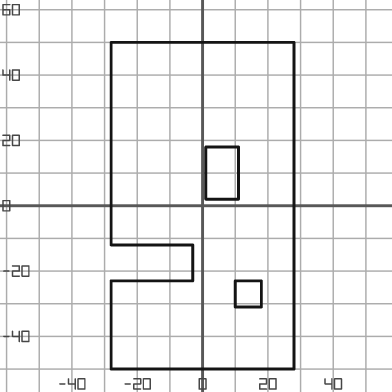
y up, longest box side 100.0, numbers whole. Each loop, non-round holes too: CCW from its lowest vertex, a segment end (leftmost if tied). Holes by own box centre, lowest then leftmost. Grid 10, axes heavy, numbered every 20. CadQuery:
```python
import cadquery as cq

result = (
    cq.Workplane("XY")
    .moveTo(-28.0, -50.0)
    .lineTo(28.0, -50.0)
    .lineTo(28.0, 50.0)
    .lineTo(-28.0, 50.0)
    .lineTo(-28.0, -12.0)
    .lineTo(-3.0, -12.0)
    .lineTo(-3.0, -23.0)
    .lineTo(-28.0, -23.0)
    .close()
    .moveTo(10.0, -31.0)
    .lineTo(18.0, -31.0)
    .lineTo(18.0, -23.0)
    .lineTo(10.0, -23.0)
    .close()
    .moveTo(1.0, 2.0)
    .lineTo(11.0, 2.0)
    .lineTo(11.0, 18.0)
    .lineTo(1.0, 18.0)
    .close()
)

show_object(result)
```